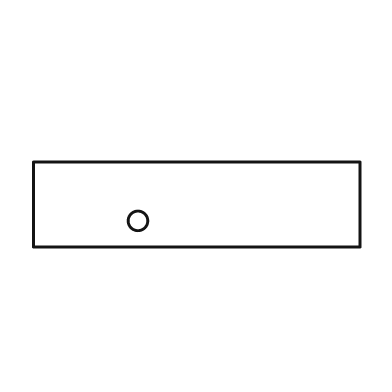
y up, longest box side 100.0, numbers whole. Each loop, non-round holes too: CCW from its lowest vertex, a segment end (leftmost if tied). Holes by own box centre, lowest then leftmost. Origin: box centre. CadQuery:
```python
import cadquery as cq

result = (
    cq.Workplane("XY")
    .moveTo(-50.0, -13.0)
    .lineTo(50.0, -13.0)
    .lineTo(50.0, 13.0)
    .lineTo(-50.0, 13.0)
    .close()
    .moveTo(-18.0, -5.0)
    .circle(3.0)
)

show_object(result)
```